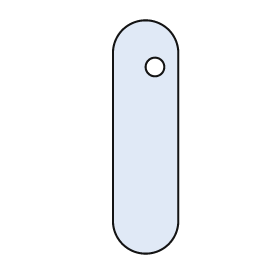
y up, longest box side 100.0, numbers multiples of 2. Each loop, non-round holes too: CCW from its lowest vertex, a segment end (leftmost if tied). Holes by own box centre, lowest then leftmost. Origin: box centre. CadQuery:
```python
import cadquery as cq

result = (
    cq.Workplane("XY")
    .moveTo(-14.0, -36.0)
    .threePointArc((0.0, -50.0), (14.0, -36.0))
    .lineTo(14.0, 36.0)
    .threePointArc((0.0, 50.0), (-14.0, 36.0))
    .close()
    .moveTo(4.0, 30.0)
    .circle(4.0)
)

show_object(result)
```